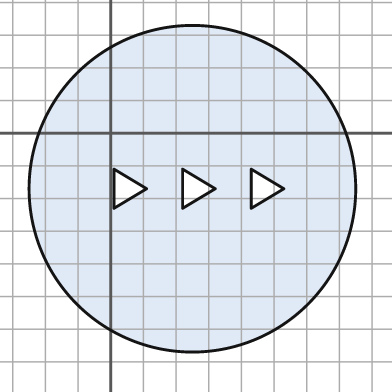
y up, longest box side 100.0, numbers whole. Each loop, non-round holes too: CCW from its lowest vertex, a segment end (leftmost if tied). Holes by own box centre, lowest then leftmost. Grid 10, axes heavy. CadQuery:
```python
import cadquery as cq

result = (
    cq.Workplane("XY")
    .moveTo(25.0, -17.0)
    .circle(50.0)
    .moveTo(1.0, -23.0)
    .lineTo(11.0, -17.0)
    .lineTo(1.0, -11.0)
    .close()
    .moveTo(22.0, -23.0)
    .lineTo(32.0, -17.0)
    .lineTo(22.0, -11.0)
    .close()
    .moveTo(43.0, -23.0)
    .lineTo(53.0, -17.0)
    .lineTo(43.0, -11.0)
    .close()
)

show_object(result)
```